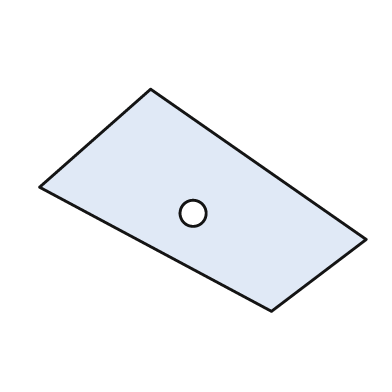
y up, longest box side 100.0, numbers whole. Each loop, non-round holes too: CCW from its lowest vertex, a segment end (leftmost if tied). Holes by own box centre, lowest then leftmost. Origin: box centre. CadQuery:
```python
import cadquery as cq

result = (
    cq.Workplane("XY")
    .moveTo(21.0, -34.0)
    .lineTo(50.0, -12.0)
    .lineTo(-16.0, 34.0)
    .lineTo(-50.0, 4.0)
    .close()
    .moveTo(-3.0, -4.0)
    .circle(4.0)
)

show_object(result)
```